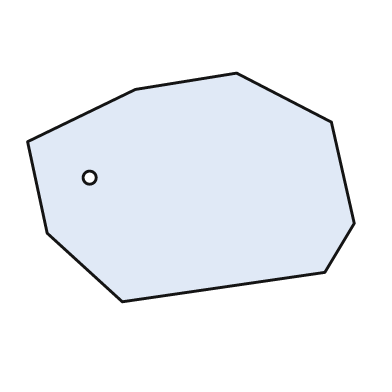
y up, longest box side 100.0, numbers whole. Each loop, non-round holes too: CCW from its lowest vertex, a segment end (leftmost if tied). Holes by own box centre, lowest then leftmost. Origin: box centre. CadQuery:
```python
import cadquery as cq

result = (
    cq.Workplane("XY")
    .moveTo(-21.0, -35.0)
    .lineTo(41.0, -26.0)
    .lineTo(50.0, -11.0)
    .lineTo(43.0, 20.0)
    .lineTo(14.0, 35.0)
    .lineTo(-17.0, 30.0)
    .lineTo(-50.0, 14.0)
    .lineTo(-44.0, -14.0)
    .close()
    .moveTo(-31.0, 3.0)
    .circle(2.0)
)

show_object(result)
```